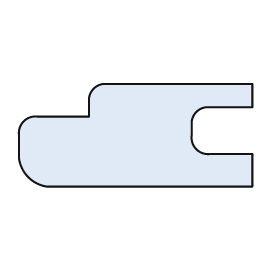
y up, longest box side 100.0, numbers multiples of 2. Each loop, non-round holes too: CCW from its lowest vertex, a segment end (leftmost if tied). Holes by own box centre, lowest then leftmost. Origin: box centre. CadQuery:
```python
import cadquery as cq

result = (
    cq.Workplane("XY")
    .moveTo(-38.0, -22.0)
    .lineTo(50.0, -22.0)
    .lineTo(50.0, -8.0)
    .lineTo(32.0, -8.0)
    .threePointArc((26.0, -6.0), (24.0, 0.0))
    .lineTo(24.0, 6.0)
    .threePointArc((26.0, 10.0), (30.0, 12.0))
    .lineTo(50.0, 12.0)
    .lineTo(50.0, 22.0)
    .lineTo(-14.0, 22.0)
    .threePointArc((-18.0, 20.0), (-20.0, 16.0))
    .lineTo(-20.0, 8.0)
    .lineTo(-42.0, 8.0)
    .threePointArc((-48.0, 6.0), (-50.0, 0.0))
    .lineTo(-50.0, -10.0)
    .threePointArc((-46.0, -18.0), (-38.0, -22.0))
    .close()
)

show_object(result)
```